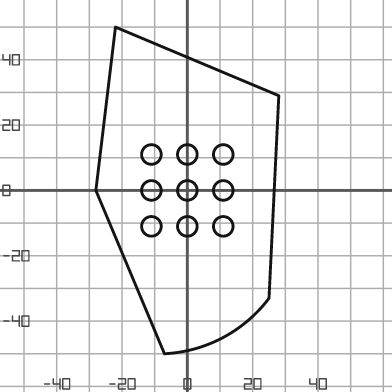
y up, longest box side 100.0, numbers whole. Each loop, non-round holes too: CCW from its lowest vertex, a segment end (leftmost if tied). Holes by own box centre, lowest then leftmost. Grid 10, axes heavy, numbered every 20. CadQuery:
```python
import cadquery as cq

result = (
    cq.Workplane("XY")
    .moveTo(-7.0, -50.0)
    .threePointArc((11.0, -45.0), (25.0, -33.0))
    .lineTo(28.0, 29.0)
    .lineTo(-22.0, 50.0)
    .lineTo(-28.0, 0.0)
    .close()
    .moveTo(-11.0, -11.0)
    .circle(3.0)
    .moveTo(0.0, -11.0)
    .circle(3.0)
    .moveTo(11.0, -11.0)
    .circle(3.0)
    .moveTo(-11.0, 0.0)
    .circle(3.0)
    .moveTo(0.0, 0.0)
    .circle(3.0)
    .moveTo(11.0, 0.0)
    .circle(3.0)
    .moveTo(-11.0, 11.0)
    .circle(3.0)
    .moveTo(0.0, 11.0)
    .circle(3.0)
    .moveTo(11.0, 11.0)
    .circle(3.0)
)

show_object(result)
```